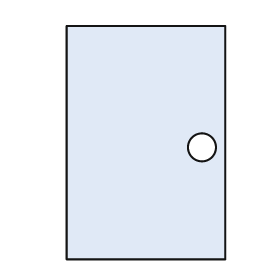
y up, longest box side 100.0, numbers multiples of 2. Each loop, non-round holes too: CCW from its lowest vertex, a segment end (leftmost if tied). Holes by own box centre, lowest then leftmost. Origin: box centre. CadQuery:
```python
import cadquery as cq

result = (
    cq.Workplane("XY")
    .moveTo(-34.0, -50.0)
    .lineTo(34.0, -50.0)
    .lineTo(34.0, 50.0)
    .lineTo(-34.0, 50.0)
    .close()
    .moveTo(24.0, -2.0)
    .circle(6.0)
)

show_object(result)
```